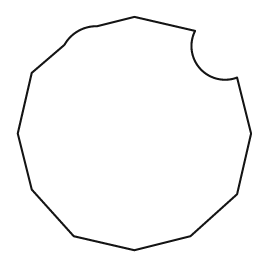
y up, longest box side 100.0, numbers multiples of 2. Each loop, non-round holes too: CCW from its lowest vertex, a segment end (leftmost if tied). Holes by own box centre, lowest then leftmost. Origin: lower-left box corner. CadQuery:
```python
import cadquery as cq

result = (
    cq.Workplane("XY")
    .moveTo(50.0, 0.0)
    .lineTo(74.0, 6.0)
    .lineTo(94.0, 24.0)
    .lineTo(100.0, 50.0)
    .lineTo(94.0, 74.0)
    .threePointArc((78.0, 78.0), (76.0, 94.0))
    .lineTo(50.0, 100.0)
    .lineTo(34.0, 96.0)
    .threePointArc((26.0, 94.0), (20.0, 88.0))
    .lineTo(6.0, 76.0)
    .lineTo(0.0, 50.0)
    .lineTo(6.0, 26.0)
    .lineTo(24.0, 6.0)
    .close()
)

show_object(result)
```